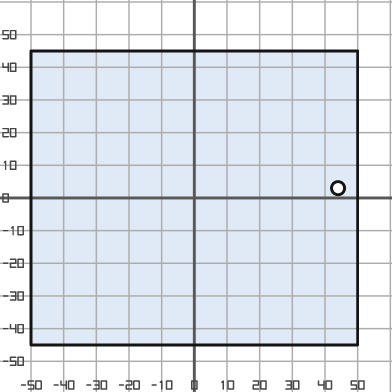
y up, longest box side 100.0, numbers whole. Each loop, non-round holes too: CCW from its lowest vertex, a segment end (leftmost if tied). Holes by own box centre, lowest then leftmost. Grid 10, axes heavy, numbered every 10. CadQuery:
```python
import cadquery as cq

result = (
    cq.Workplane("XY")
    .moveTo(-50.0, -45.0)
    .lineTo(50.0, -45.0)
    .lineTo(50.0, 45.0)
    .lineTo(-50.0, 45.0)
    .close()
    .moveTo(44.0, 3.0)
    .circle(2.0)
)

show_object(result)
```